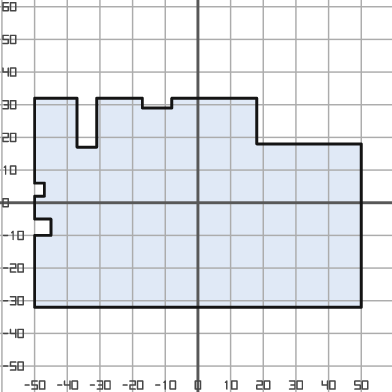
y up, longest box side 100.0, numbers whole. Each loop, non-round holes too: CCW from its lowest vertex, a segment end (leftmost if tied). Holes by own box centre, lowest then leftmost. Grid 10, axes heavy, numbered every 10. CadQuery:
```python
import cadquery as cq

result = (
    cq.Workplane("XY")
    .moveTo(-50.0, -32.0)
    .lineTo(50.0, -32.0)
    .lineTo(50.0, 18.0)
    .lineTo(18.0, 18.0)
    .lineTo(18.0, 32.0)
    .lineTo(-8.0, 32.0)
    .lineTo(-8.0, 29.0)
    .lineTo(-17.0, 29.0)
    .lineTo(-17.0, 32.0)
    .lineTo(-31.0, 32.0)
    .lineTo(-31.0, 17.0)
    .lineTo(-37.0, 17.0)
    .lineTo(-37.0, 32.0)
    .lineTo(-50.0, 32.0)
    .lineTo(-50.0, 6.0)
    .lineTo(-47.0, 6.0)
    .lineTo(-47.0, 2.0)
    .lineTo(-50.0, 2.0)
    .lineTo(-50.0, -5.0)
    .lineTo(-45.0, -5.0)
    .lineTo(-45.0, -10.0)
    .lineTo(-50.0, -10.0)
    .close()
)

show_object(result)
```